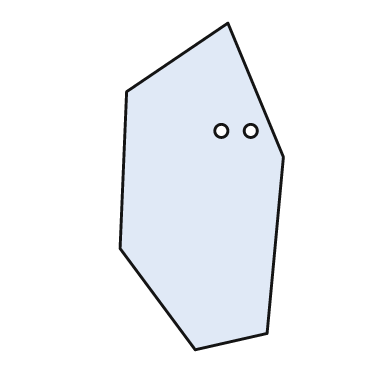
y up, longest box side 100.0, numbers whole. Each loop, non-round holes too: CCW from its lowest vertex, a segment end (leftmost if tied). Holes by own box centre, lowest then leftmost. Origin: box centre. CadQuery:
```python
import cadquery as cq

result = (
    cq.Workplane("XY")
    .moveTo(-2.0, -50.0)
    .lineTo(20.0, -45.0)
    .lineTo(25.0, 9.0)
    .lineTo(8.0, 50.0)
    .lineTo(-23.0, 29.0)
    .lineTo(-25.0, -19.0)
    .close()
    .moveTo(6.0, 17.0)
    .circle(2.0)
    .moveTo(15.0, 17.0)
    .circle(2.0)
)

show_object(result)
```